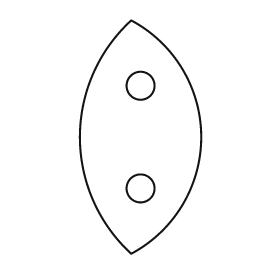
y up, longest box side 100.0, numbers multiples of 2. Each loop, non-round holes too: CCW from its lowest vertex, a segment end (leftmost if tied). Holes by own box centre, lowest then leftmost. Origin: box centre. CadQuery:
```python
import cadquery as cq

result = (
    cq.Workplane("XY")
    .moveTo(-4.0, -50.0)
    .threePointArc((26.0, 0.0), (-4.0, 50.0))
    .threePointArc((-26.0, 0.0), (-4.0, -50.0))
    .close()
    .moveTo(0.0, -22.0)
    .circle(6.0)
    .moveTo(0.0, 22.0)
    .circle(6.0)
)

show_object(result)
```